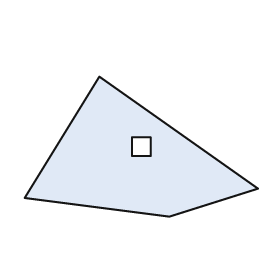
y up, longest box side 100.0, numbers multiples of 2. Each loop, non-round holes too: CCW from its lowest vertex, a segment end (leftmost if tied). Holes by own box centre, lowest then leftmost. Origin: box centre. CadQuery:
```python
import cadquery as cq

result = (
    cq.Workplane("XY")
    .moveTo(12.0, -30.0)
    .lineTo(50.0, -18.0)
    .lineTo(-18.0, 30.0)
    .lineTo(-50.0, -22.0)
    .close()
    .moveTo(-4.0, -4.0)
    .lineTo(4.0, -4.0)
    .lineTo(4.0, 4.0)
    .lineTo(-4.0, 4.0)
    .close()
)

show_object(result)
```